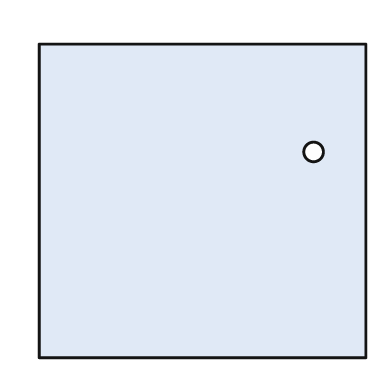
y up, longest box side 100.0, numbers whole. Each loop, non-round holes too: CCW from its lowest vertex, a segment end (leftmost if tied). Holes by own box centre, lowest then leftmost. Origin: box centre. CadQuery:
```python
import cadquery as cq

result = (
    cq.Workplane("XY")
    .moveTo(-50.0, -48.0)
    .lineTo(50.0, -48.0)
    .lineTo(50.0, 48.0)
    .lineTo(-50.0, 48.0)
    .close()
    .moveTo(34.0, 15.0)
    .circle(3.0)
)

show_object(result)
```